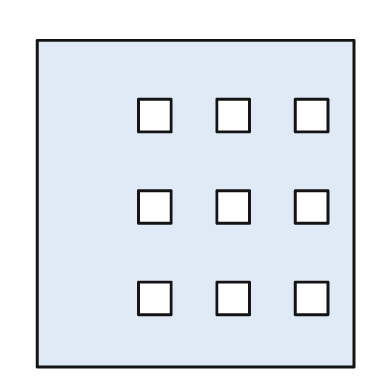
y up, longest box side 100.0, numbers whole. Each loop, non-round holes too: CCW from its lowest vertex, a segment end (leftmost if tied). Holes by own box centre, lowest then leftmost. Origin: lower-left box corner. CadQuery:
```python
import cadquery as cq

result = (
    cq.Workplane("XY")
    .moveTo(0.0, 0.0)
    .lineTo(97.0, 0.0)
    .lineTo(97.0, 100.0)
    .lineTo(0.0, 100.0)
    .close()
    .moveTo(31.0, 16.0)
    .lineTo(41.0, 16.0)
    .lineTo(41.0, 26.0)
    .lineTo(31.0, 26.0)
    .close()
    .moveTo(55.0, 16.0)
    .lineTo(65.0, 16.0)
    .lineTo(65.0, 26.0)
    .lineTo(55.0, 26.0)
    .close()
    .moveTo(79.0, 16.0)
    .lineTo(89.0, 16.0)
    .lineTo(89.0, 26.0)
    .lineTo(79.0, 26.0)
    .close()
    .moveTo(31.0, 44.0)
    .lineTo(41.0, 44.0)
    .lineTo(41.0, 54.0)
    .lineTo(31.0, 54.0)
    .close()
    .moveTo(55.0, 44.0)
    .lineTo(65.0, 44.0)
    .lineTo(65.0, 54.0)
    .lineTo(55.0, 54.0)
    .close()
    .moveTo(79.0, 44.0)
    .lineTo(89.0, 44.0)
    .lineTo(89.0, 54.0)
    .lineTo(79.0, 54.0)
    .close()
    .moveTo(31.0, 72.0)
    .lineTo(41.0, 72.0)
    .lineTo(41.0, 82.0)
    .lineTo(31.0, 82.0)
    .close()
    .moveTo(55.0, 72.0)
    .lineTo(65.0, 72.0)
    .lineTo(65.0, 82.0)
    .lineTo(55.0, 82.0)
    .close()
    .moveTo(79.0, 72.0)
    .lineTo(89.0, 72.0)
    .lineTo(89.0, 82.0)
    .lineTo(79.0, 82.0)
    .close()
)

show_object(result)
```